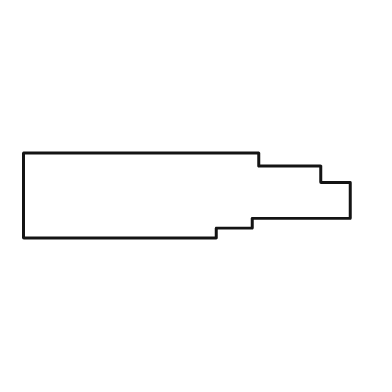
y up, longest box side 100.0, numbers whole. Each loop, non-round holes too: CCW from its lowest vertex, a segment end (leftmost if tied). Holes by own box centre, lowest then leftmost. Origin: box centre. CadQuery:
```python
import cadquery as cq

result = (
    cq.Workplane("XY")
    .moveTo(-50.0, -13.0)
    .lineTo(9.0, -13.0)
    .lineTo(9.0, -10.0)
    .lineTo(20.0, -10.0)
    .lineTo(20.0, -7.0)
    .lineTo(50.0, -7.0)
    .lineTo(50.0, 4.0)
    .lineTo(41.0, 4.0)
    .lineTo(41.0, 9.0)
    .lineTo(22.0, 9.0)
    .lineTo(22.0, 13.0)
    .lineTo(-50.0, 13.0)
    .close()
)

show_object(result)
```